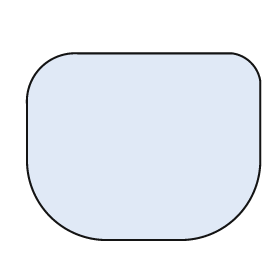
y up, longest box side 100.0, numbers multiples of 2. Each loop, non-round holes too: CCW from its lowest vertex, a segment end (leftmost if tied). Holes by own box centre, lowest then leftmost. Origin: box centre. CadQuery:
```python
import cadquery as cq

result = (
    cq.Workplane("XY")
    .moveTo(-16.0, -40.0)
    .lineTo(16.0, -40.0)
    .threePointArc((40.0, -30.0), (50.0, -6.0))
    .lineTo(50.0, 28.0)
    .threePointArc((46.0, 36.0), (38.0, 40.0))
    .lineTo(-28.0, 40.0)
    .threePointArc((-44.0, 34.0), (-50.0, 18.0))
    .lineTo(-50.0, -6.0)
    .threePointArc((-40.0, -30.0), (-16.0, -40.0))
    .close()
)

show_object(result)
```